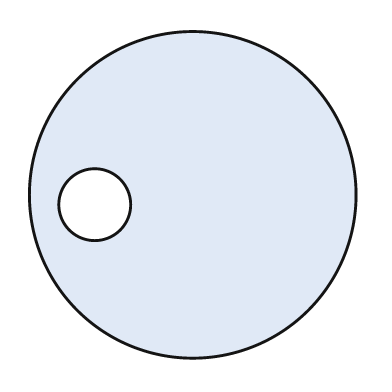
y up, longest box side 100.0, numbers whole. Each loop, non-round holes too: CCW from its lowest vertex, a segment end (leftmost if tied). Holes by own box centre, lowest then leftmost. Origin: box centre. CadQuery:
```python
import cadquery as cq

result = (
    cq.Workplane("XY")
    .moveTo(0.0, 0.0)
    .circle(50.0)
    .moveTo(-30.0, -3.0)
    .circle(11.0)
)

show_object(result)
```